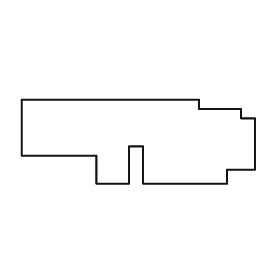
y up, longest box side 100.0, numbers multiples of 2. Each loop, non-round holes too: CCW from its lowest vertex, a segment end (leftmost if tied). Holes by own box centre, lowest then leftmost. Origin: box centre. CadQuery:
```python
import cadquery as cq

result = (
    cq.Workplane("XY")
    .moveTo(-18.0, -18.0)
    .lineTo(-4.0, -18.0)
    .lineTo(-4.0, -2.0)
    .lineTo(2.0, -2.0)
    .lineTo(2.0, -18.0)
    .lineTo(38.0, -18.0)
    .lineTo(38.0, -12.0)
    .lineTo(50.0, -12.0)
    .lineTo(50.0, 10.0)
    .lineTo(44.0, 10.0)
    .lineTo(44.0, 14.0)
    .lineTo(26.0, 14.0)
    .lineTo(26.0, 18.0)
    .lineTo(-50.0, 18.0)
    .lineTo(-50.0, -6.0)
    .lineTo(-18.0, -6.0)
    .close()
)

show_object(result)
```